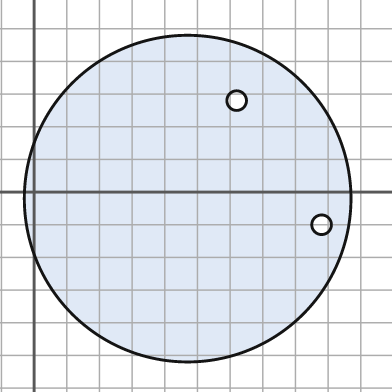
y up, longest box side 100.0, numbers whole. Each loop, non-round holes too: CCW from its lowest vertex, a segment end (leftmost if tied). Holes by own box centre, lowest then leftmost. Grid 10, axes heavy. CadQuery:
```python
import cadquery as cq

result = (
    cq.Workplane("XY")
    .moveTo(47.0, -2.0)
    .circle(50.0)
    .moveTo(88.0, -10.0)
    .circle(3.0)
    .moveTo(62.0, 28.0)
    .circle(3.0)
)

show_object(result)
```